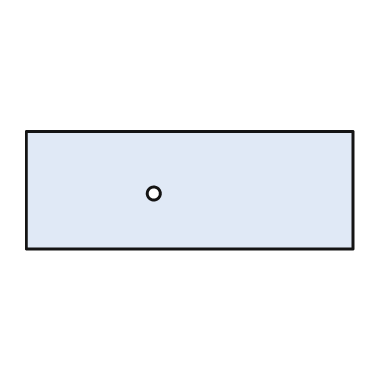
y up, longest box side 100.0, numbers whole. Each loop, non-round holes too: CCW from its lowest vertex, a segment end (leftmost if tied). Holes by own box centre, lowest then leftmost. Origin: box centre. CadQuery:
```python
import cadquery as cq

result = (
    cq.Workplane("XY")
    .moveTo(-50.0, -18.0)
    .lineTo(50.0, -18.0)
    .lineTo(50.0, 18.0)
    .lineTo(-50.0, 18.0)
    .close()
    .moveTo(-11.0, -1.0)
    .circle(2.0)
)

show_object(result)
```